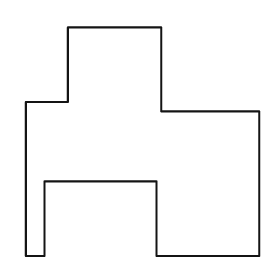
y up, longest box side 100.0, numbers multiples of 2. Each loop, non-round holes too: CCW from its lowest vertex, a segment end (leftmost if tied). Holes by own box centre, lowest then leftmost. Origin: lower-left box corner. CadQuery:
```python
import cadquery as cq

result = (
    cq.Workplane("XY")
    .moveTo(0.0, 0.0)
    .lineTo(8.0, 0.0)
    .lineTo(8.0, 32.0)
    .lineTo(56.0, 32.0)
    .lineTo(56.0, 0.0)
    .lineTo(100.0, 0.0)
    .lineTo(100.0, 62.0)
    .lineTo(58.0, 62.0)
    .lineTo(58.0, 98.0)
    .lineTo(18.0, 98.0)
    .lineTo(18.0, 66.0)
    .lineTo(0.0, 66.0)
    .close()
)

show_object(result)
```